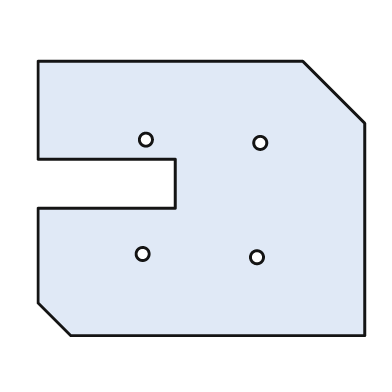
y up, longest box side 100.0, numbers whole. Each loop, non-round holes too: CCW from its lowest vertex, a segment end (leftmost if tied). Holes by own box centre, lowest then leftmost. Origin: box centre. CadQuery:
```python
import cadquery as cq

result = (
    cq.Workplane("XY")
    .moveTo(-40.0, -42.0)
    .lineTo(50.0, -42.0)
    .lineTo(50.0, 23.0)
    .lineTo(31.0, 42.0)
    .lineTo(-50.0, 42.0)
    .lineTo(-50.0, 12.0)
    .lineTo(-8.0, 12.0)
    .lineTo(-8.0, -3.0)
    .lineTo(-50.0, -3.0)
    .lineTo(-50.0, -32.0)
    .close()
    .moveTo(17.0, -18.0)
    .circle(2.0)
    .moveTo(-18.0, -17.0)
    .circle(2.0)
    .moveTo(18.0, 17.0)
    .circle(2.0)
    .moveTo(-17.0, 18.0)
    .circle(2.0)
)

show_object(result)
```